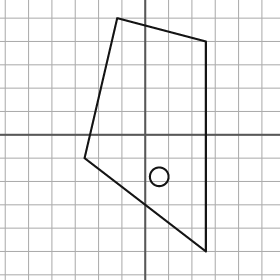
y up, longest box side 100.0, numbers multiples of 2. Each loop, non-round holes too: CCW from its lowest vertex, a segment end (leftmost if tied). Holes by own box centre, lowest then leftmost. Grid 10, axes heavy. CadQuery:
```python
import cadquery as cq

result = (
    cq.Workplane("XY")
    .moveTo(26.0, -50.0)
    .lineTo(26.0, 40.0)
    .lineTo(-12.0, 50.0)
    .lineTo(-26.0, -10.0)
    .close()
    .moveTo(6.0, -18.0)
    .circle(4.0)
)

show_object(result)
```